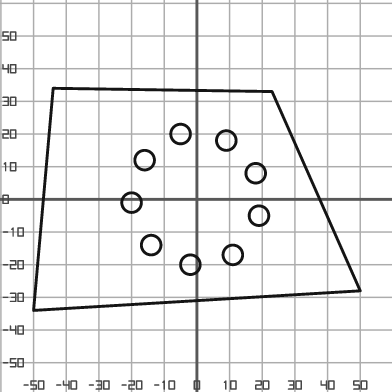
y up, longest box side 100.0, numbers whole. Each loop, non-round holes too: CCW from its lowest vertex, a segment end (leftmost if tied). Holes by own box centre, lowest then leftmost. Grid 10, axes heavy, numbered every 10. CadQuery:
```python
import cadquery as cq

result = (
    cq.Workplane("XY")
    .moveTo(-50.0, -34.0)
    .lineTo(50.0, -28.0)
    .lineTo(23.0, 33.0)
    .lineTo(-44.0, 34.0)
    .close()
    .moveTo(-2.0, -20.0)
    .circle(3.0)
    .moveTo(11.0, -17.0)
    .circle(3.0)
    .moveTo(-14.0, -14.0)
    .circle(3.0)
    .moveTo(19.0, -5.0)
    .circle(3.0)
    .moveTo(-20.0, -1.0)
    .circle(3.0)
    .moveTo(18.0, 8.0)
    .circle(3.0)
    .moveTo(-16.0, 12.0)
    .circle(3.0)
    .moveTo(9.0, 18.0)
    .circle(3.0)
    .moveTo(-5.0, 20.0)
    .circle(3.0)
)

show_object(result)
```